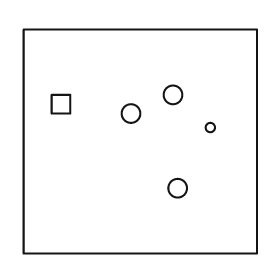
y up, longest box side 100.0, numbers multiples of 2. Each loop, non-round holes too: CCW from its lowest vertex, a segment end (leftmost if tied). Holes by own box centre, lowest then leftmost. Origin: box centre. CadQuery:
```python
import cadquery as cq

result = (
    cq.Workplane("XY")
    .moveTo(-50.0, -48.0)
    .lineTo(50.0, -48.0)
    .lineTo(50.0, 48.0)
    .lineTo(-50.0, 48.0)
    .close()
    .moveTo(16.0, -20.0)
    .circle(4.0)
    .moveTo(30.0, 6.0)
    .circle(2.0)
    .moveTo(-4.0, 12.0)
    .circle(4.0)
    .moveTo(-38.0, 12.0)
    .lineTo(-30.0, 12.0)
    .lineTo(-30.0, 20.0)
    .lineTo(-38.0, 20.0)
    .close()
    .moveTo(14.0, 20.0)
    .circle(4.0)
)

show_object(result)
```